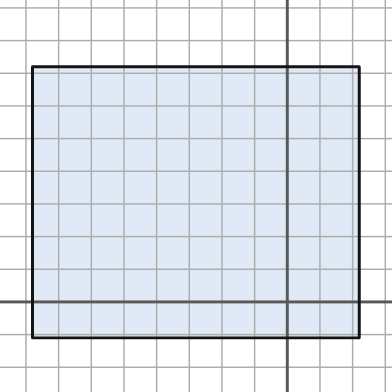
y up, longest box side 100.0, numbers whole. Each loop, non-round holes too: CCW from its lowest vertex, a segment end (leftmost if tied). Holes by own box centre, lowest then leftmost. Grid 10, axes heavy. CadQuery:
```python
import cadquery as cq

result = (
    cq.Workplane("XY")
    .moveTo(-78.0, -11.0)
    .lineTo(22.0, -11.0)
    .lineTo(22.0, 72.0)
    .lineTo(-78.0, 72.0)
    .close()
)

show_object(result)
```